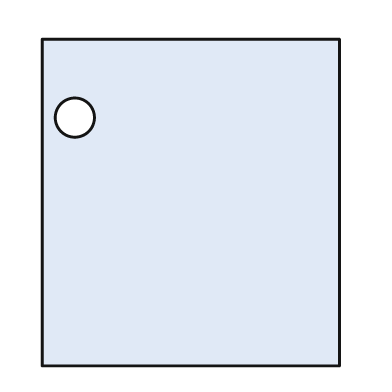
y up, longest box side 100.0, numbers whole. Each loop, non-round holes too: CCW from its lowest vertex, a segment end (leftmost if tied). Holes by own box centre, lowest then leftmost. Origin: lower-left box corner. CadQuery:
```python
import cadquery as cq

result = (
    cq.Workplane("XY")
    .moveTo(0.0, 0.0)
    .lineTo(91.0, 0.0)
    .lineTo(91.0, 100.0)
    .lineTo(0.0, 100.0)
    .close()
    .moveTo(10.0, 76.0)
    .circle(6.0)
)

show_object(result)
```